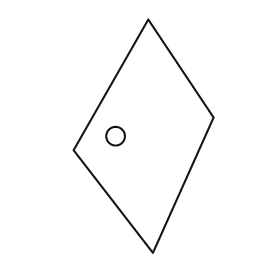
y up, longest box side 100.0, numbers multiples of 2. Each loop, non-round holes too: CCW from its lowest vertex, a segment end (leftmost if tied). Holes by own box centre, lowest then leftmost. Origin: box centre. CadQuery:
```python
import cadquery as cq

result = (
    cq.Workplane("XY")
    .moveTo(4.0, -50.0)
    .lineTo(30.0, 8.0)
    .lineTo(2.0, 50.0)
    .lineTo(-30.0, -6.0)
    .close()
    .moveTo(-12.0, 0.0)
    .circle(4.0)
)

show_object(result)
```